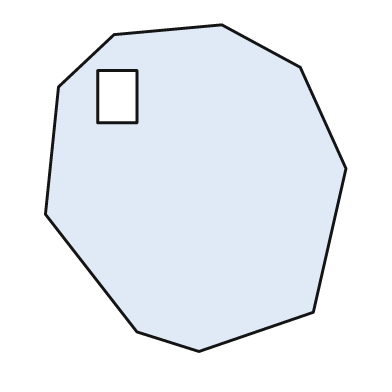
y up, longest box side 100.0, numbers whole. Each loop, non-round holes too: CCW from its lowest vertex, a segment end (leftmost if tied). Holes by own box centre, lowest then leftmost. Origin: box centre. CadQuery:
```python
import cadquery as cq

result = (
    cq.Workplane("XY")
    .moveTo(1.0, -50.0)
    .lineTo(36.0, -38.0)
    .lineTo(46.0, 6.0)
    .lineTo(32.0, 37.0)
    .lineTo(8.0, 50.0)
    .lineTo(-25.0, 47.0)
    .lineTo(-42.0, 31.0)
    .lineTo(-46.0, -8.0)
    .lineTo(-18.0, -44.0)
    .close()
    .moveTo(-30.0, 20.0)
    .lineTo(-18.0, 20.0)
    .lineTo(-18.0, 36.0)
    .lineTo(-30.0, 36.0)
    .close()
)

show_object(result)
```